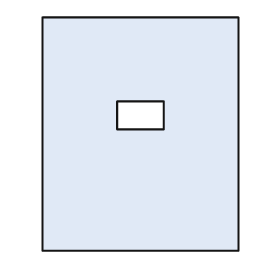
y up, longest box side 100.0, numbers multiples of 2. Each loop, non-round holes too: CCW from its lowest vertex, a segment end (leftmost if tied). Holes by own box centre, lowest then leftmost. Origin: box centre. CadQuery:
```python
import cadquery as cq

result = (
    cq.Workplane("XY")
    .moveTo(-42.0, -50.0)
    .lineTo(42.0, -50.0)
    .lineTo(42.0, 50.0)
    .lineTo(-42.0, 50.0)
    .close()
    .moveTo(-10.0, 2.0)
    .lineTo(10.0, 2.0)
    .lineTo(10.0, 14.0)
    .lineTo(-10.0, 14.0)
    .close()
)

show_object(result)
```